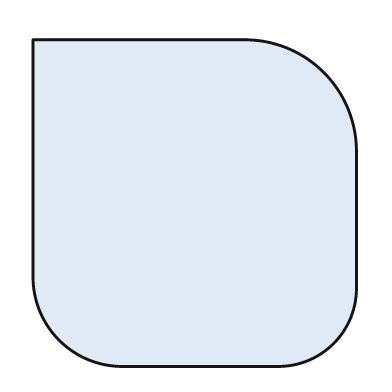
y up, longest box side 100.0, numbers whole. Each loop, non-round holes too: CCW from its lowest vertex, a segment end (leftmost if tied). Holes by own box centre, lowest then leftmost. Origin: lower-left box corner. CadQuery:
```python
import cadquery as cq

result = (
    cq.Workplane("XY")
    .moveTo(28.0, 0.0)
    .lineTo(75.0, 0.0)
    .threePointArc((92.0, 7.0), (99.0, 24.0))
    .lineTo(99.0, 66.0)
    .threePointArc((89.0, 90.0), (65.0, 100.0))
    .lineTo(0.0, 100.0)
    .lineTo(0.0, 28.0)
    .threePointArc((8.0, 8.0), (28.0, 0.0))
    .close()
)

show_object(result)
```